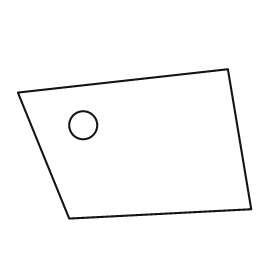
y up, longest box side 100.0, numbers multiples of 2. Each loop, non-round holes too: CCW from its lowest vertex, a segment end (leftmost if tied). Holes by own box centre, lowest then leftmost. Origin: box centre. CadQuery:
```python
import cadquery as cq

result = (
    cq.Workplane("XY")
    .moveTo(-28.0, -32.0)
    .lineTo(50.0, -28.0)
    .lineTo(40.0, 32.0)
    .lineTo(-50.0, 22.0)
    .close()
    .moveTo(-22.0, 8.0)
    .circle(6.0)
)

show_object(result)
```